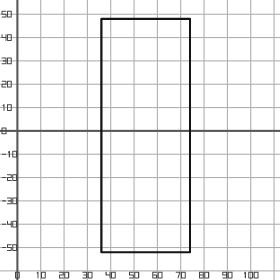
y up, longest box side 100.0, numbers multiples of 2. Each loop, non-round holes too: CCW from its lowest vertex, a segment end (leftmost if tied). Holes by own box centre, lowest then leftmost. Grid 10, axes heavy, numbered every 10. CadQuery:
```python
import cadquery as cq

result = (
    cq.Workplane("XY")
    .moveTo(36.0, -52.0)
    .lineTo(74.0, -52.0)
    .lineTo(74.0, 48.0)
    .lineTo(36.0, 48.0)
    .close()
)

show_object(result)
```